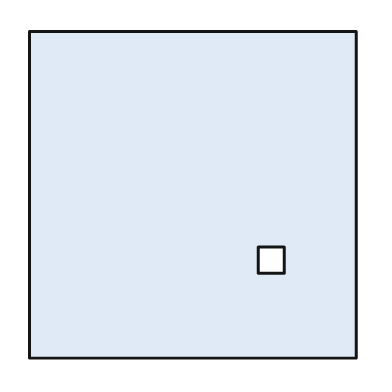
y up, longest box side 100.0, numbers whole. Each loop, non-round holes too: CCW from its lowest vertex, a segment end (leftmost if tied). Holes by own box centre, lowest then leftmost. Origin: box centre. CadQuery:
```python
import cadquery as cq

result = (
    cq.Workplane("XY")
    .moveTo(-50.0, -50.0)
    .lineTo(50.0, -50.0)
    .lineTo(50.0, 50.0)
    .lineTo(-50.0, 50.0)
    .close()
    .moveTo(20.0, -24.0)
    .lineTo(28.0, -24.0)
    .lineTo(28.0, -16.0)
    .lineTo(20.0, -16.0)
    .close()
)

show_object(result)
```